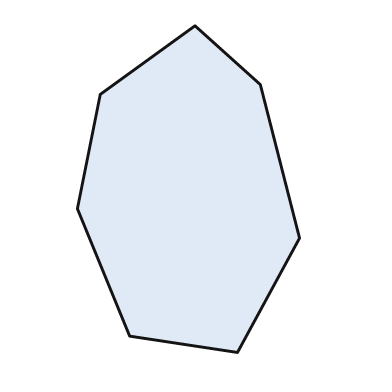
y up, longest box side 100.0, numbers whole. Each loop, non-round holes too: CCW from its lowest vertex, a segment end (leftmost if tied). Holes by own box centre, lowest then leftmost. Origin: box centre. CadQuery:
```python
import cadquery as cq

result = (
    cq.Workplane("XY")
    .moveTo(15.0, -50.0)
    .lineTo(34.0, -15.0)
    .lineTo(22.0, 32.0)
    .lineTo(2.0, 50.0)
    .lineTo(-27.0, 29.0)
    .lineTo(-34.0, -6.0)
    .lineTo(-18.0, -45.0)
    .close()
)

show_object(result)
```